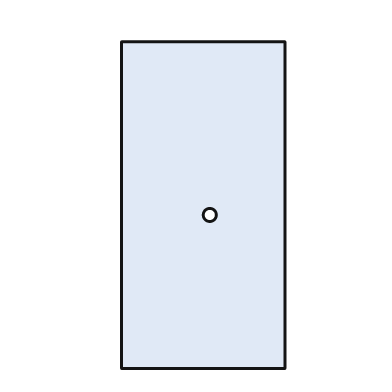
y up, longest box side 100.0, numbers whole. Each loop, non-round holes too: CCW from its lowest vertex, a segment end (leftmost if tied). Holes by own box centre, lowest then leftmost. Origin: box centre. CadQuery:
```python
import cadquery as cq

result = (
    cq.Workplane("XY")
    .moveTo(-25.0, -50.0)
    .lineTo(25.0, -50.0)
    .lineTo(25.0, 50.0)
    .lineTo(-25.0, 50.0)
    .close()
    .moveTo(2.0, -3.0)
    .circle(2.0)
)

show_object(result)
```